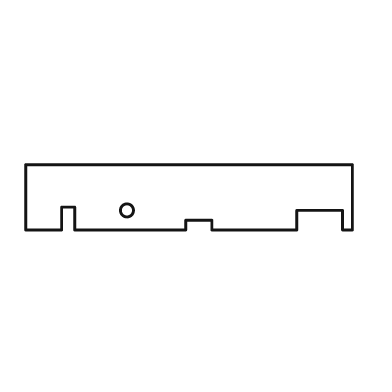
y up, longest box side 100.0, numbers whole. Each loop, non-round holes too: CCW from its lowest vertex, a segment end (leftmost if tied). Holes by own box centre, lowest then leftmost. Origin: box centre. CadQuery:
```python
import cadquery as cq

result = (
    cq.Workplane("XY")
    .moveTo(-50.0, -10.0)
    .lineTo(-39.0, -10.0)
    .lineTo(-39.0, -3.0)
    .lineTo(-35.0, -3.0)
    .lineTo(-35.0, -10.0)
    .lineTo(-1.0, -10.0)
    .lineTo(-1.0, -7.0)
    .lineTo(7.0, -7.0)
    .lineTo(7.0, -10.0)
    .lineTo(33.0, -10.0)
    .lineTo(33.0, -4.0)
    .lineTo(47.0, -4.0)
    .lineTo(47.0, -10.0)
    .lineTo(50.0, -10.0)
    .lineTo(50.0, 10.0)
    .lineTo(-50.0, 10.0)
    .close()
    .moveTo(-19.0, -4.0)
    .circle(2.0)
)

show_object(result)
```